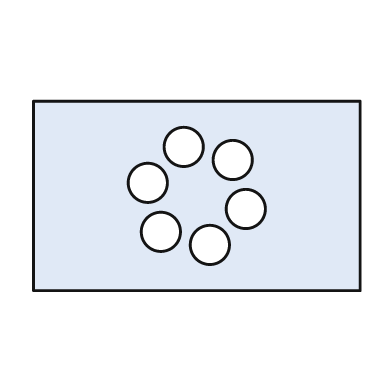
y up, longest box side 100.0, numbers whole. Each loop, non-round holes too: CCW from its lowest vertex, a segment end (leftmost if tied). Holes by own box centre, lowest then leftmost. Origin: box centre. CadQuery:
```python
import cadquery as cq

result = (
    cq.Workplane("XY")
    .moveTo(-50.0, -29.0)
    .lineTo(50.0, -29.0)
    .lineTo(50.0, 29.0)
    .lineTo(-50.0, 29.0)
    .close()
    .moveTo(4.0, -15.0)
    .circle(6.0)
    .moveTo(-11.0, -11.0)
    .circle(6.0)
    .moveTo(15.0, -4.0)
    .circle(6.0)
    .moveTo(-15.0, 4.0)
    .circle(6.0)
    .moveTo(11.0, 11.0)
    .circle(6.0)
    .moveTo(-4.0, 15.0)
    .circle(6.0)
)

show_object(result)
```